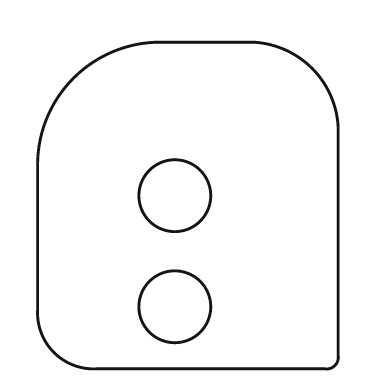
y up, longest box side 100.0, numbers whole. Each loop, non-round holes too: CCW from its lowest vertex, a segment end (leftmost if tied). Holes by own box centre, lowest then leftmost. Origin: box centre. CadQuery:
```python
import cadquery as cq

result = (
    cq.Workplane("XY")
    .moveTo(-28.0, -50.0)
    .lineTo(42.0, -50.0)
    .threePointArc((45.0, -49.0), (46.0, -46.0))
    .lineTo(46.0, 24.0)
    .threePointArc((38.0, 42.0), (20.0, 50.0))
    .lineTo(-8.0, 50.0)
    .threePointArc((-35.0, 39.0), (-46.0, 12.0))
    .lineTo(-46.0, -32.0)
    .threePointArc((-41.0, -45.0), (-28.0, -50.0))
    .close()
    .moveTo(-4.0, -31.0)
    .circle(11.0)
    .moveTo(-4.0, 3.0)
    .circle(11.0)
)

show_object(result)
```